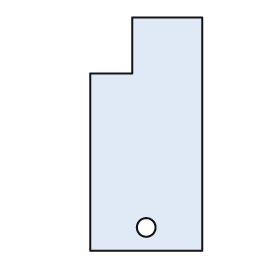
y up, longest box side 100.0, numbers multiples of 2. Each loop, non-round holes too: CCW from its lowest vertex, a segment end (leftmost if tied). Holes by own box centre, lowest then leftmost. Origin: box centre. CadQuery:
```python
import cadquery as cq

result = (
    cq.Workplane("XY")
    .moveTo(-24.0, -50.0)
    .lineTo(24.0, -50.0)
    .lineTo(24.0, 50.0)
    .lineTo(-6.0, 50.0)
    .lineTo(-6.0, 26.0)
    .lineTo(-24.0, 26.0)
    .close()
    .moveTo(0.0, -40.0)
    .circle(4.0)
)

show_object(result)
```